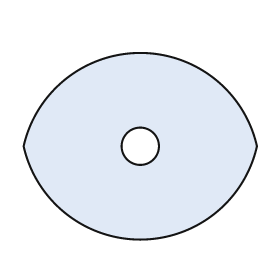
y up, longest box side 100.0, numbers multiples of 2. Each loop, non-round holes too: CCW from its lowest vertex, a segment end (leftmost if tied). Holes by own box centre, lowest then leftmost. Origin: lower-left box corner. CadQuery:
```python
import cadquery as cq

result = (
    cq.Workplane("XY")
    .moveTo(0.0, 40.0)
    .threePointArc((50.0, 0.0), (100.0, 40.0))
    .threePointArc((50.0, 80.0), (0.0, 40.0))
    .close()
    .moveTo(50.0, 40.0)
    .circle(8.0)
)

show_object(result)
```